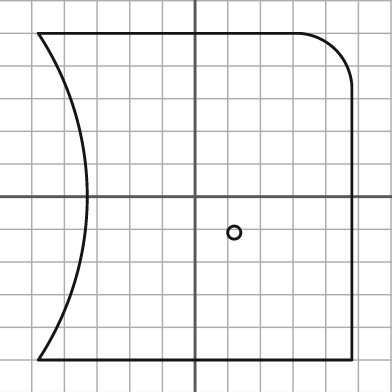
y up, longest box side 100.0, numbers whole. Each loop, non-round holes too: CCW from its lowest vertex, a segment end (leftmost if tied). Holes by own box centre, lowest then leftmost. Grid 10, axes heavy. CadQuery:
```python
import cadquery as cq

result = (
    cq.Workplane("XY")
    .moveTo(-48.0, -50.0)
    .lineTo(48.0, -50.0)
    .lineTo(48.0, 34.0)
    .threePointArc((43.0, 45.0), (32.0, 50.0))
    .lineTo(-48.0, 50.0)
    .threePointArc((-33.0, 0.0), (-48.0, -50.0))
    .close()
    .moveTo(12.0, -11.0)
    .circle(2.0)
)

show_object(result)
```